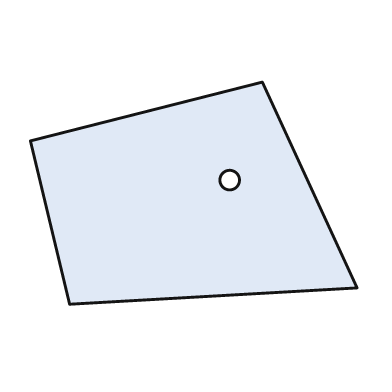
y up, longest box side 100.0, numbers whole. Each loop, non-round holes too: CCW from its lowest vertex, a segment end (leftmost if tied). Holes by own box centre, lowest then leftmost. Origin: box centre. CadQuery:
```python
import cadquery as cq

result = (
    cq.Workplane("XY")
    .moveTo(-38.0, -34.0)
    .lineTo(50.0, -29.0)
    .lineTo(21.0, 34.0)
    .lineTo(-50.0, 16.0)
    .close()
    .moveTo(11.0, 4.0)
    .circle(3.0)
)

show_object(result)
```